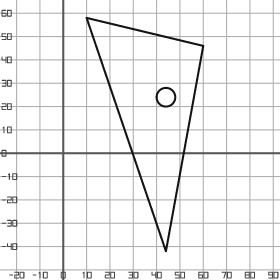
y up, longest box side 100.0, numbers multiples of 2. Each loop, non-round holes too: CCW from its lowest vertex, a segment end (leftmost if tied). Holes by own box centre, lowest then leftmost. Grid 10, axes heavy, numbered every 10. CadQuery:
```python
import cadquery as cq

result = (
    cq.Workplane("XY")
    .moveTo(44.0, -42.0)
    .lineTo(60.0, 46.0)
    .lineTo(10.0, 58.0)
    .close()
    .moveTo(44.0, 24.0)
    .circle(4.0)
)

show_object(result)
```